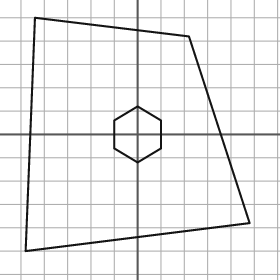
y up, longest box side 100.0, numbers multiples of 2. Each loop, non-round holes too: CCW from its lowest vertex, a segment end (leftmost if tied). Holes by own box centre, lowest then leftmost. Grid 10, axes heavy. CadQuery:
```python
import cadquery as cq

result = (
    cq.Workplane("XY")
    .moveTo(-48.0, -50.0)
    .lineTo(48.0, -38.0)
    .lineTo(22.0, 42.0)
    .lineTo(-44.0, 50.0)
    .close()
    .moveTo(0.0, -12.0)
    .lineTo(10.0, -6.0)
    .lineTo(10.0, 6.0)
    .lineTo(0.0, 12.0)
    .lineTo(-10.0, 6.0)
    .lineTo(-10.0, -6.0)
    .close()
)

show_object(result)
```